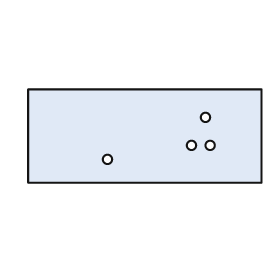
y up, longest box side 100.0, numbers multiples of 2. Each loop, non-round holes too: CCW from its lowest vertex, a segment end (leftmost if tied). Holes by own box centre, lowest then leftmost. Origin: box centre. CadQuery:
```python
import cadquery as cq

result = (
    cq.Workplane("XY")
    .moveTo(-50.0, -20.0)
    .lineTo(50.0, -20.0)
    .lineTo(50.0, 20.0)
    .lineTo(-50.0, 20.0)
    .close()
    .moveTo(-16.0, -10.0)
    .circle(2.0)
    .moveTo(20.0, -4.0)
    .circle(2.0)
    .moveTo(28.0, -4.0)
    .circle(2.0)
    .moveTo(26.0, 8.0)
    .circle(2.0)
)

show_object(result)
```